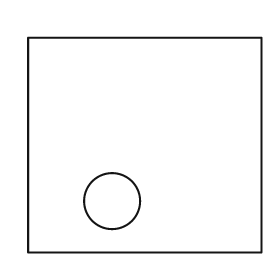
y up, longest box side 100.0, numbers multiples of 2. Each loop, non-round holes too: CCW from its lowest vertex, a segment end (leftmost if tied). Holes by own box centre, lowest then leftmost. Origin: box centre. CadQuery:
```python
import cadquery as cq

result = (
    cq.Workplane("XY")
    .moveTo(-50.0, -46.0)
    .lineTo(50.0, -46.0)
    .lineTo(50.0, 46.0)
    .lineTo(-50.0, 46.0)
    .close()
    .moveTo(-14.0, -24.0)
    .circle(12.0)
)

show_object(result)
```